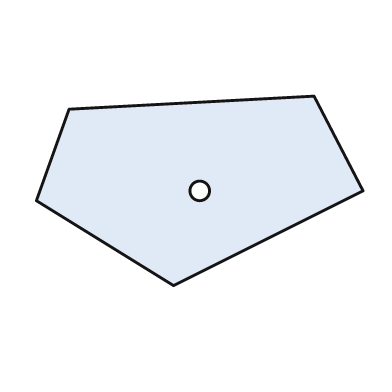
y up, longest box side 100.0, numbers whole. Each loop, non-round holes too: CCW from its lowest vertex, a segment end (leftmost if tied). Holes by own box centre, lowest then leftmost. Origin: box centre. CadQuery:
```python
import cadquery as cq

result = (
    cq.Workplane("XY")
    .moveTo(-8.0, -29.0)
    .lineTo(50.0, 0.0)
    .lineTo(35.0, 29.0)
    .lineTo(-40.0, 25.0)
    .lineTo(-50.0, -3.0)
    .close()
    .moveTo(0.0, 0.0)
    .circle(3.0)
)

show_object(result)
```